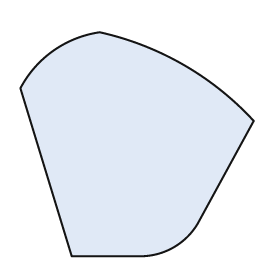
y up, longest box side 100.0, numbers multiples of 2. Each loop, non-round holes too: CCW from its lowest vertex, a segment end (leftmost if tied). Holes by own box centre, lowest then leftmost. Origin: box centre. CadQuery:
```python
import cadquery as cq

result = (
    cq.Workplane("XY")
    .moveTo(-28.0, -48.0)
    .lineTo(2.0, -48.0)
    .threePointArc((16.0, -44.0), (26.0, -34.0))
    .lineTo(50.0, 10.0)
    .threePointArc((20.0, 34.0), (-16.0, 48.0))
    .threePointArc((-36.0, 40.0), (-50.0, 24.0))
    .close()
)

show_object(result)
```